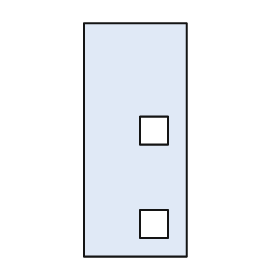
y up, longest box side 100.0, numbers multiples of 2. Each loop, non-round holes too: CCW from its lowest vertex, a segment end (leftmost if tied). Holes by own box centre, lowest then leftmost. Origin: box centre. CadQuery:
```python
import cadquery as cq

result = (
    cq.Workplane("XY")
    .moveTo(-22.0, -50.0)
    .lineTo(22.0, -50.0)
    .lineTo(22.0, 50.0)
    .lineTo(-22.0, 50.0)
    .close()
    .moveTo(2.0, -42.0)
    .lineTo(14.0, -42.0)
    .lineTo(14.0, -30.0)
    .lineTo(2.0, -30.0)
    .close()
    .moveTo(2.0, -2.0)
    .lineTo(14.0, -2.0)
    .lineTo(14.0, 10.0)
    .lineTo(2.0, 10.0)
    .close()
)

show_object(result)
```